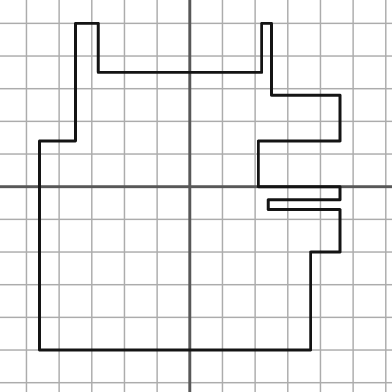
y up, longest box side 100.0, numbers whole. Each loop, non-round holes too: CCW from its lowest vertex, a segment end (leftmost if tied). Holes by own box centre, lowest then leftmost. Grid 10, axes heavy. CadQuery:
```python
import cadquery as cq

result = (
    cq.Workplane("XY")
    .moveTo(-46.0, -50.0)
    .lineTo(37.0, -50.0)
    .lineTo(37.0, -20.0)
    .lineTo(46.0, -20.0)
    .lineTo(46.0, -7.0)
    .lineTo(24.0, -7.0)
    .lineTo(24.0, -4.0)
    .lineTo(46.0, -4.0)
    .lineTo(46.0, 0.0)
    .lineTo(21.0, 0.0)
    .lineTo(21.0, 14.0)
    .lineTo(46.0, 14.0)
    .lineTo(46.0, 28.0)
    .lineTo(25.0, 28.0)
    .lineTo(25.0, 50.0)
    .lineTo(22.0, 50.0)
    .lineTo(22.0, 35.0)
    .lineTo(-28.0, 35.0)
    .lineTo(-28.0, 50.0)
    .lineTo(-35.0, 50.0)
    .lineTo(-35.0, 14.0)
    .lineTo(-46.0, 14.0)
    .close()
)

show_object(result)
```